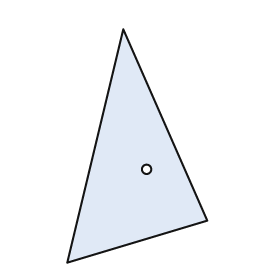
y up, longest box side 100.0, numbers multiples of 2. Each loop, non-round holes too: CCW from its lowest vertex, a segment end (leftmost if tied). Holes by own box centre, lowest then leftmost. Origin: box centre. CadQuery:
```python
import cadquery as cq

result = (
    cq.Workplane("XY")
    .moveTo(-30.0, -50.0)
    .lineTo(30.0, -32.0)
    .lineTo(-6.0, 50.0)
    .close()
    .moveTo(4.0, -10.0)
    .circle(2.0)
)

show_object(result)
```